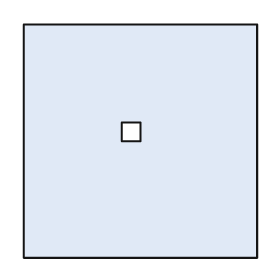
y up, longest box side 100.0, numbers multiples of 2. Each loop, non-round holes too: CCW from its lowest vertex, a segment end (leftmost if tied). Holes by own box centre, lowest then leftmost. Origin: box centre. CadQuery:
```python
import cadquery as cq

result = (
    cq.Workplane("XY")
    .moveTo(-50.0, -50.0)
    .lineTo(50.0, -50.0)
    .lineTo(50.0, 50.0)
    .lineTo(-50.0, 50.0)
    .close()
    .moveTo(-8.0, 0.0)
    .lineTo(0.0, 0.0)
    .lineTo(0.0, 8.0)
    .lineTo(-8.0, 8.0)
    .close()
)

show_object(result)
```